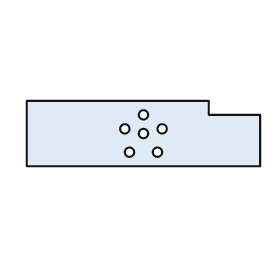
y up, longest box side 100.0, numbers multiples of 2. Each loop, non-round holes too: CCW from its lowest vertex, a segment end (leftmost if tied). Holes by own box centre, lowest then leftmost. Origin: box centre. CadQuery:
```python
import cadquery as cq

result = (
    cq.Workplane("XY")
    .moveTo(-50.0, -14.0)
    .lineTo(50.0, -14.0)
    .lineTo(50.0, 8.0)
    .lineTo(28.0, 8.0)
    .lineTo(28.0, 14.0)
    .lineTo(-50.0, 14.0)
    .close()
    .moveTo(-6.0, -8.0)
    .circle(2.0)
    .moveTo(6.0, -8.0)
    .circle(2.0)
    .moveTo(0.0, 0.0)
    .circle(2.0)
    .moveTo(-8.0, 2.0)
    .circle(2.0)
    .moveTo(8.0, 2.0)
    .circle(2.0)
    .moveTo(0.0, 8.0)
    .circle(2.0)
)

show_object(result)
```